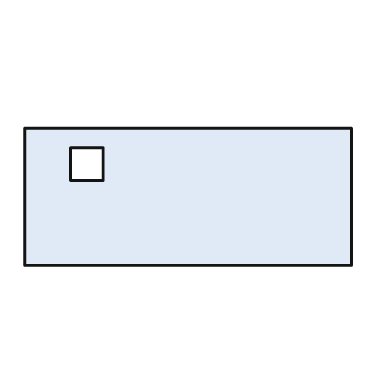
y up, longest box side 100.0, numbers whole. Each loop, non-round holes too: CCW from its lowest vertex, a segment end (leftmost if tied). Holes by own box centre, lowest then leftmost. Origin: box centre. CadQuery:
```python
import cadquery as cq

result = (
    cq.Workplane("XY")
    .moveTo(-50.0, -21.0)
    .lineTo(50.0, -21.0)
    .lineTo(50.0, 21.0)
    .lineTo(-50.0, 21.0)
    .close()
    .moveTo(-36.0, 5.0)
    .lineTo(-26.0, 5.0)
    .lineTo(-26.0, 15.0)
    .lineTo(-36.0, 15.0)
    .close()
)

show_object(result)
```